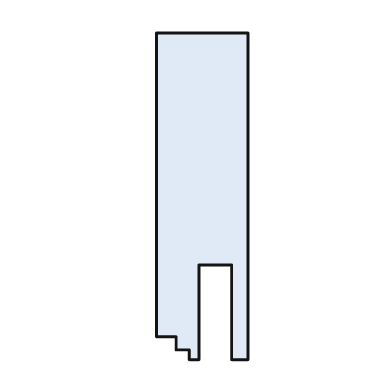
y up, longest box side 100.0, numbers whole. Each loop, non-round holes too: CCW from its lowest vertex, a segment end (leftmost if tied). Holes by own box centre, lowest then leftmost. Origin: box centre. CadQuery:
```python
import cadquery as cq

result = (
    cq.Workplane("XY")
    .moveTo(-4.0, -50.0)
    .lineTo(-1.0, -50.0)
    .lineTo(-1.0, -21.0)
    .lineTo(9.0, -21.0)
    .lineTo(9.0, -50.0)
    .lineTo(14.0, -50.0)
    .lineTo(14.0, 50.0)
    .lineTo(-14.0, 50.0)
    .lineTo(-14.0, -43.0)
    .lineTo(-8.0, -43.0)
    .lineTo(-8.0, -47.0)
    .lineTo(-4.0, -47.0)
    .close()
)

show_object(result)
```